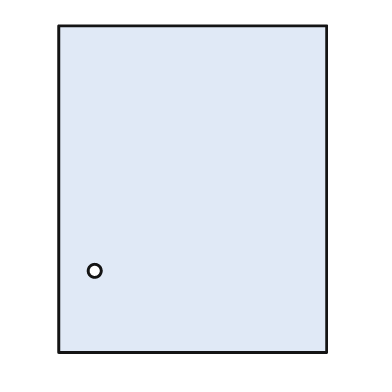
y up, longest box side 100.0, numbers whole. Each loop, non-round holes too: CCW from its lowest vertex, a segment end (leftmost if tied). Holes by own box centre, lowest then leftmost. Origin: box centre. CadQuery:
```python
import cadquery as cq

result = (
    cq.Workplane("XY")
    .moveTo(-41.0, -50.0)
    .lineTo(41.0, -50.0)
    .lineTo(41.0, 50.0)
    .lineTo(-41.0, 50.0)
    .close()
    .moveTo(-30.0, -25.0)
    .circle(2.0)
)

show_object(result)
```